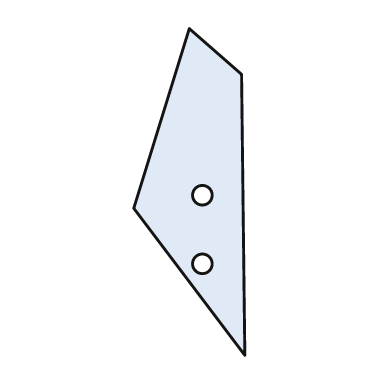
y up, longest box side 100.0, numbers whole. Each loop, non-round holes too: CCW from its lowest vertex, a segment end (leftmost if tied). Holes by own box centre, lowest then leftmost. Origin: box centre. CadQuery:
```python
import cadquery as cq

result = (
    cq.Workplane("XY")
    .moveTo(17.0, -50.0)
    .lineTo(16.0, 36.0)
    .lineTo(0.0, 50.0)
    .lineTo(-17.0, -5.0)
    .close()
    .moveTo(4.0, -22.0)
    .circle(3.0)
    .moveTo(4.0, -1.0)
    .circle(3.0)
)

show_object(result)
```